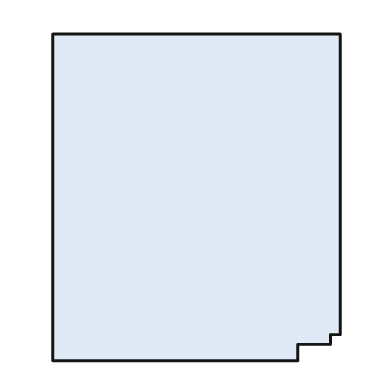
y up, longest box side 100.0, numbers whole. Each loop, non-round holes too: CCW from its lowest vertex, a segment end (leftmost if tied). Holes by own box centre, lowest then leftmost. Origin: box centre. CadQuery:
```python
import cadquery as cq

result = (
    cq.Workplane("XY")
    .moveTo(-44.0, -50.0)
    .lineTo(31.0, -50.0)
    .lineTo(31.0, -45.0)
    .lineTo(41.0, -45.0)
    .lineTo(41.0, -42.0)
    .lineTo(44.0, -42.0)
    .lineTo(44.0, 50.0)
    .lineTo(-44.0, 50.0)
    .close()
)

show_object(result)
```